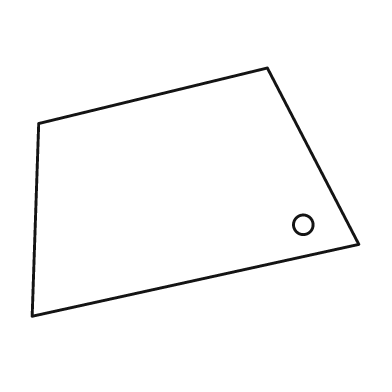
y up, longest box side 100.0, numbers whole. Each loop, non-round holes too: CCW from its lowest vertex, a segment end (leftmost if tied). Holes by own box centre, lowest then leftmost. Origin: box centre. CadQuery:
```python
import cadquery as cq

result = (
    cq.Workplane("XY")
    .moveTo(-50.0, -38.0)
    .lineTo(50.0, -16.0)
    .lineTo(22.0, 38.0)
    .lineTo(-48.0, 21.0)
    .close()
    .moveTo(33.0, -10.0)
    .circle(3.0)
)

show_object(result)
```